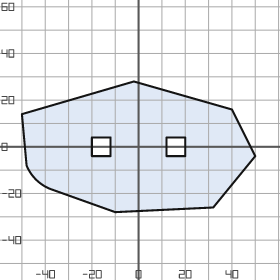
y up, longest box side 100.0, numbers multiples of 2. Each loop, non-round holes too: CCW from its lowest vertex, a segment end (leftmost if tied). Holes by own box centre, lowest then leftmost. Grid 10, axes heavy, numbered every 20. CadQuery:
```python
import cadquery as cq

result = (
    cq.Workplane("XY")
    .moveTo(-10.0, -28.0)
    .lineTo(32.0, -26.0)
    .lineTo(50.0, -4.0)
    .lineTo(40.0, 16.0)
    .lineTo(-2.0, 28.0)
    .lineTo(-50.0, 14.0)
    .lineTo(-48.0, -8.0)
    .threePointArc((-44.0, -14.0), (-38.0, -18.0))
    .close()
    .moveTo(-20.0, -4.0)
    .lineTo(-12.0, -4.0)
    .lineTo(-12.0, 4.0)
    .lineTo(-20.0, 4.0)
    .close()
    .moveTo(12.0, -4.0)
    .lineTo(20.0, -4.0)
    .lineTo(20.0, 4.0)
    .lineTo(12.0, 4.0)
    .close()
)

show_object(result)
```